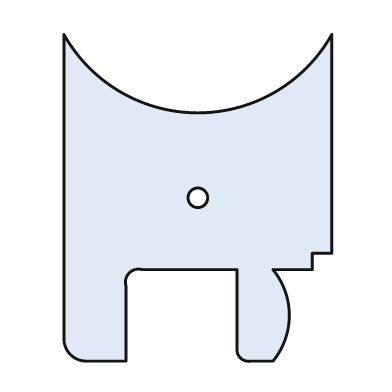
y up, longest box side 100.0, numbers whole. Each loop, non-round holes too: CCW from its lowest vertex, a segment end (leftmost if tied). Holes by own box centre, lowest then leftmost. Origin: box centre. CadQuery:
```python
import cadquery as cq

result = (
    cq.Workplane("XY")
    .moveTo(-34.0, -50.0)
    .lineTo(-22.0, -50.0)
    .lineTo(-22.0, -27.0)
    .threePointArc((-21.0, -23.0), (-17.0, -22.0))
    .lineTo(12.0, -22.0)
    .lineTo(12.0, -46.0)
    .threePointArc((13.0, -49.0), (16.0, -50.0))
    .lineTo(23.0, -50.0)
    .threePointArc((28.0, -36.0), (23.0, -22.0))
    .lineTo(35.0, -22.0)
    .lineTo(35.0, -17.0)
    .lineTo(41.0, -17.0)
    .lineTo(41.0, 50.0)
    .threePointArc((0.0, 26.0), (-41.0, 50.0))
    .lineTo(-41.0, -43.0)
    .threePointArc((-39.0, -48.0), (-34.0, -50.0))
    .close()
    .moveTo(0.0, 0.0)
    .circle(3.0)
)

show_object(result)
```